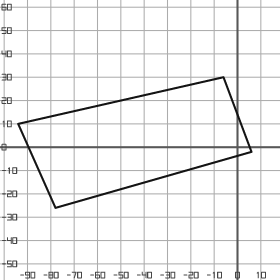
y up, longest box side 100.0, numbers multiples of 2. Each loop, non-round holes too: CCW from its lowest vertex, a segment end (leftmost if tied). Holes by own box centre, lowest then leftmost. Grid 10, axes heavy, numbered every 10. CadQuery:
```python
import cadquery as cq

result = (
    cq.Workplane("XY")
    .moveTo(-78.0, -26.0)
    .lineTo(6.0, -2.0)
    .lineTo(-6.0, 30.0)
    .lineTo(-94.0, 10.0)
    .close()
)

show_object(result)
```